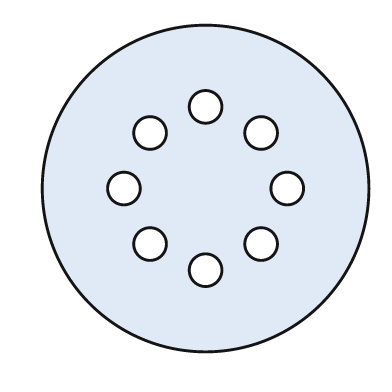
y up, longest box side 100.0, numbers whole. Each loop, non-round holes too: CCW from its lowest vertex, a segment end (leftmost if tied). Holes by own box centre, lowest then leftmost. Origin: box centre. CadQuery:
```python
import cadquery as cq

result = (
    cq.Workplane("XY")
    .moveTo(0.0, 0.0)
    .circle(50.0)
    .moveTo(0.0, -25.0)
    .circle(5.0)
    .moveTo(-17.0, -17.0)
    .circle(5.0)
    .moveTo(17.0, -17.0)
    .circle(5.0)
    .moveTo(-25.0, 0.0)
    .circle(5.0)
    .moveTo(25.0, 0.0)
    .circle(5.0)
    .moveTo(-17.0, 17.0)
    .circle(5.0)
    .moveTo(17.0, 17.0)
    .circle(5.0)
    .moveTo(0.0, 25.0)
    .circle(5.0)
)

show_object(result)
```